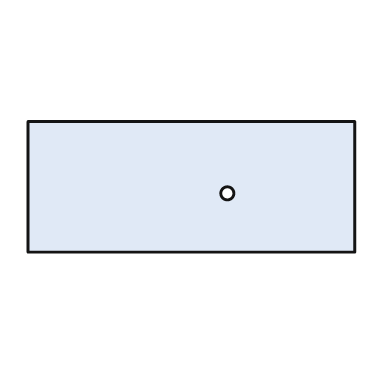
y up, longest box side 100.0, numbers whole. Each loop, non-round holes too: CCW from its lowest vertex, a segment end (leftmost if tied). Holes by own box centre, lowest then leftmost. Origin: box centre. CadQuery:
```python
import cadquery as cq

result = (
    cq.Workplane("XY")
    .moveTo(-50.0, -20.0)
    .lineTo(50.0, -20.0)
    .lineTo(50.0, 20.0)
    .lineTo(-50.0, 20.0)
    .close()
    .moveTo(11.0, -2.0)
    .circle(2.0)
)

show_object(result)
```